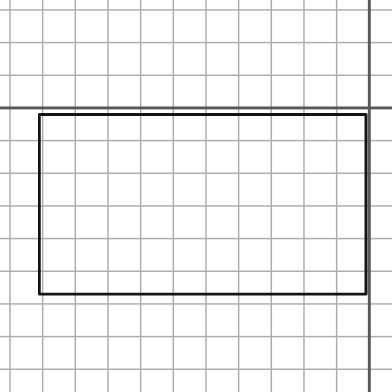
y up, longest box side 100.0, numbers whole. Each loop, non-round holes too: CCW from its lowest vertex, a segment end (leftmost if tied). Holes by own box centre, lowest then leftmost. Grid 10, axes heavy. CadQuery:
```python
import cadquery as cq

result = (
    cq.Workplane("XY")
    .moveTo(-101.0, -57.0)
    .lineTo(-1.0, -57.0)
    .lineTo(-1.0, -2.0)
    .lineTo(-101.0, -2.0)
    .close()
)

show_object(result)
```